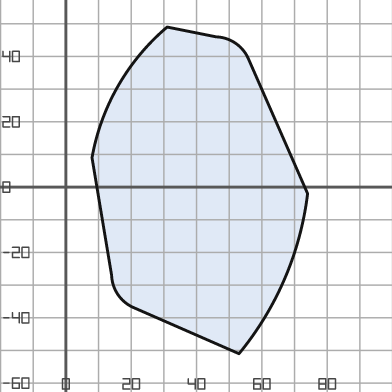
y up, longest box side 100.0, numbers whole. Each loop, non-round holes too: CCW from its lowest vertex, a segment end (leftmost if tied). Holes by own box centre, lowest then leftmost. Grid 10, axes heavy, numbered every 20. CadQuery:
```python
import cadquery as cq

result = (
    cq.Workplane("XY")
    .moveTo(53.0, -51.0)
    .threePointArc((67.0, -28.0), (74.0, -2.0))
    .lineTo(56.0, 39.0)
    .threePointArc((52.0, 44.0), (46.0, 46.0))
    .lineTo(31.0, 49.0)
    .threePointArc((16.0, 31.0), (8.0, 9.0))
    .lineTo(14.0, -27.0)
    .threePointArc((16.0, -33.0), (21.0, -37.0))
    .close()
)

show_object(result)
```